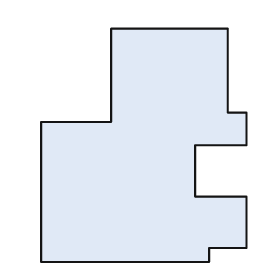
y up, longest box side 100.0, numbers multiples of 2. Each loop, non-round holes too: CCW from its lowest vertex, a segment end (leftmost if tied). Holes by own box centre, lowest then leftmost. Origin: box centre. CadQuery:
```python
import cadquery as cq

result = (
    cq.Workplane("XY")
    .moveTo(-44.0, -50.0)
    .lineTo(28.0, -50.0)
    .lineTo(28.0, -44.0)
    .lineTo(44.0, -44.0)
    .lineTo(44.0, -22.0)
    .lineTo(22.0, -22.0)
    .lineTo(22.0, 0.0)
    .lineTo(44.0, 0.0)
    .lineTo(44.0, 14.0)
    .lineTo(36.0, 14.0)
    .lineTo(36.0, 50.0)
    .lineTo(-14.0, 50.0)
    .lineTo(-14.0, 10.0)
    .lineTo(-44.0, 10.0)
    .close()
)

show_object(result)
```